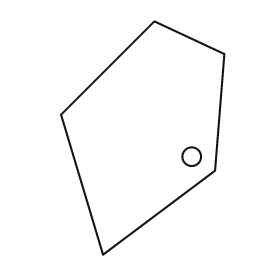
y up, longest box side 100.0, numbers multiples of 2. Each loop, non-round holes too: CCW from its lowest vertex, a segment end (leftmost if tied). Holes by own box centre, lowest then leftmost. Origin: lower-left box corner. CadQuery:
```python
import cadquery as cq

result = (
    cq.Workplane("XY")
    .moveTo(18.0, 0.0)
    .lineTo(66.0, 36.0)
    .lineTo(70.0, 86.0)
    .lineTo(40.0, 100.0)
    .lineTo(0.0, 60.0)
    .close()
    .moveTo(56.0, 42.0)
    .circle(4.0)
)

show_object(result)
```